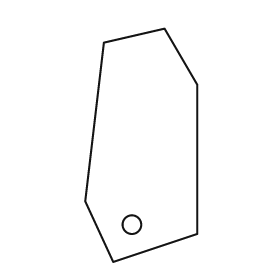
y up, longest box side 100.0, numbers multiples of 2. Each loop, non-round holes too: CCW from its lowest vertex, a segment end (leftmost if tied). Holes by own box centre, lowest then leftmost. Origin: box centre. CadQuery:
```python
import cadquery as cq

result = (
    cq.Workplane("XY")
    .moveTo(-12.0, -50.0)
    .lineTo(24.0, -38.0)
    .lineTo(24.0, 26.0)
    .lineTo(10.0, 50.0)
    .lineTo(-16.0, 44.0)
    .lineTo(-24.0, -24.0)
    .close()
    .moveTo(-4.0, -34.0)
    .circle(4.0)
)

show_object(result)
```